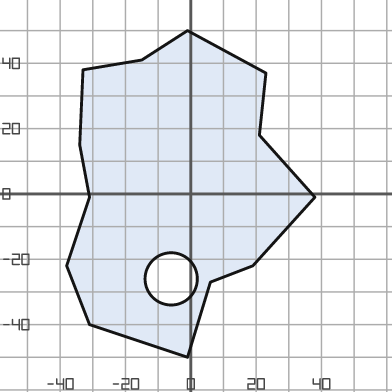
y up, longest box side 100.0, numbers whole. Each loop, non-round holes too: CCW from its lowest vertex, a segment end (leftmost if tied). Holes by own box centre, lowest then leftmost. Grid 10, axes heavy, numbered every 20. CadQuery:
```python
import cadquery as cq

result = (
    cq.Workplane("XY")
    .moveTo(-1.0, -50.0)
    .lineTo(6.0, -27.0)
    .lineTo(19.0, -22.0)
    .lineTo(38.0, -1.0)
    .lineTo(21.0, 18.0)
    .lineTo(23.0, 37.0)
    .lineTo(-1.0, 50.0)
    .lineTo(-15.0, 41.0)
    .lineTo(-33.0, 38.0)
    .lineTo(-34.0, 15.0)
    .lineTo(-31.0, -1.0)
    .lineTo(-38.0, -22.0)
    .lineTo(-31.0, -40.0)
    .close()
    .moveTo(-6.0, -26.0)
    .circle(8.0)
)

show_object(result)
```